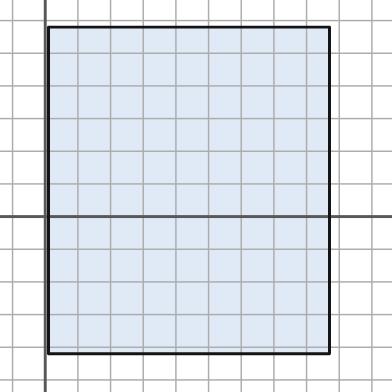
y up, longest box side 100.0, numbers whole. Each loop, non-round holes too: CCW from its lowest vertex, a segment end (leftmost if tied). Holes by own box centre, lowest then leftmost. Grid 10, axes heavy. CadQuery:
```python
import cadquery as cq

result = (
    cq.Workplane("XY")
    .moveTo(1.0, -42.0)
    .lineTo(87.0, -42.0)
    .lineTo(87.0, 58.0)
    .lineTo(1.0, 58.0)
    .close()
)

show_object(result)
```